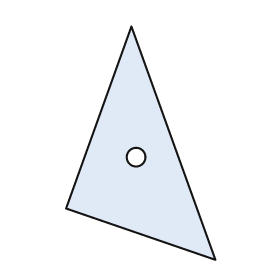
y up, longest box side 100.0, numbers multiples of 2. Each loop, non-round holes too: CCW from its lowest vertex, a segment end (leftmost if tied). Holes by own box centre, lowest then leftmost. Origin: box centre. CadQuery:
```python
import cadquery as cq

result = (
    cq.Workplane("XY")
    .moveTo(32.0, -50.0)
    .lineTo(-4.0, 50.0)
    .lineTo(-32.0, -28.0)
    .close()
    .moveTo(-2.0, -6.0)
    .circle(4.0)
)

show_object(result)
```